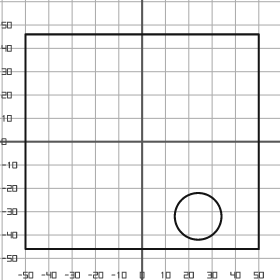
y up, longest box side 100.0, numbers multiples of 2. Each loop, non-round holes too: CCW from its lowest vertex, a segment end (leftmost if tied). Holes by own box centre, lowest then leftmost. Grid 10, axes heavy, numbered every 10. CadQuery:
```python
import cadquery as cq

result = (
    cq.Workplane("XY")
    .moveTo(-50.0, -46.0)
    .lineTo(50.0, -46.0)
    .lineTo(50.0, 46.0)
    .lineTo(-50.0, 46.0)
    .close()
    .moveTo(24.0, -32.0)
    .circle(10.0)
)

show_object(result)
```